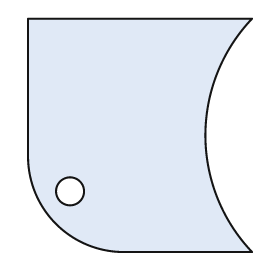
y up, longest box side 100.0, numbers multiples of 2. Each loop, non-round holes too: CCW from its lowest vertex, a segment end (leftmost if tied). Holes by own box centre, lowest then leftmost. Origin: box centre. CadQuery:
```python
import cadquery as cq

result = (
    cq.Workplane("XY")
    .moveTo(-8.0, -50.0)
    .lineTo(48.0, -50.0)
    .threePointArc((28.0, 0.0), (48.0, 50.0))
    .lineTo(-48.0, 50.0)
    .lineTo(-48.0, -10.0)
    .threePointArc((-36.0, -38.0), (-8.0, -50.0))
    .close()
    .moveTo(-30.0, -24.0)
    .circle(6.0)
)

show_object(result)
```